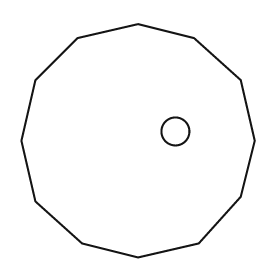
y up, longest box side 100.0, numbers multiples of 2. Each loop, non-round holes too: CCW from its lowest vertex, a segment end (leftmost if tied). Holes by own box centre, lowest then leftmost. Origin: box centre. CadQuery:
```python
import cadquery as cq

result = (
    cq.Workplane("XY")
    .moveTo(0.0, -50.0)
    .lineTo(26.0, -44.0)
    .lineTo(44.0, -24.0)
    .lineTo(50.0, 0.0)
    .lineTo(44.0, 26.0)
    .lineTo(24.0, 44.0)
    .lineTo(0.0, 50.0)
    .lineTo(-26.0, 44.0)
    .lineTo(-44.0, 26.0)
    .lineTo(-50.0, 0.0)
    .lineTo(-44.0, -26.0)
    .lineTo(-24.0, -44.0)
    .close()
    .moveTo(16.0, 4.0)
    .circle(6.0)
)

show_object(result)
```